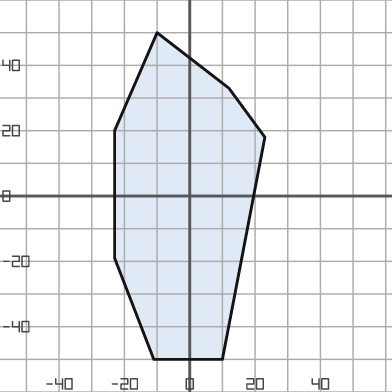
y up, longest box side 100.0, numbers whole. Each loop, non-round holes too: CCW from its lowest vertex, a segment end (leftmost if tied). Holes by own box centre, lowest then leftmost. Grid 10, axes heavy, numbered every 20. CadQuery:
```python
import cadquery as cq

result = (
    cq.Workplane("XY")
    .moveTo(-11.0, -50.0)
    .lineTo(10.0, -50.0)
    .lineTo(23.0, 18.0)
    .lineTo(12.0, 33.0)
    .lineTo(-10.0, 50.0)
    .lineTo(-23.0, 20.0)
    .lineTo(-23.0, -19.0)
    .close()
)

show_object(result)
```